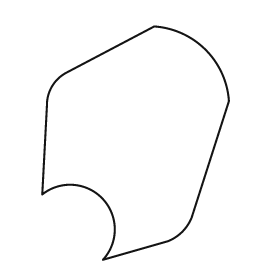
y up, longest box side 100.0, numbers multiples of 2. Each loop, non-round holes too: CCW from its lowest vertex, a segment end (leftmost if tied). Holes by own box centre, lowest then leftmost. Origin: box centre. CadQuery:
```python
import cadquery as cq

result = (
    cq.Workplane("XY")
    .moveTo(-14.0, -50.0)
    .lineTo(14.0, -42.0)
    .threePointArc((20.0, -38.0), (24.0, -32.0))
    .lineTo(40.0, 18.0)
    .threePointArc((30.0, 40.0), (8.0, 50.0))
    .lineTo(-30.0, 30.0)
    .threePointArc((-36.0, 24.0), (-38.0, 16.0))
    .lineTo(-40.0, -22.0)
    .threePointArc((-14.0, -24.0), (-14.0, -50.0))
    .close()
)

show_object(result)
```